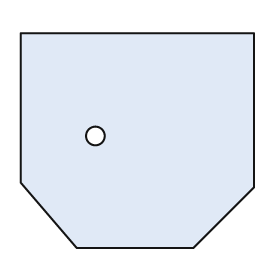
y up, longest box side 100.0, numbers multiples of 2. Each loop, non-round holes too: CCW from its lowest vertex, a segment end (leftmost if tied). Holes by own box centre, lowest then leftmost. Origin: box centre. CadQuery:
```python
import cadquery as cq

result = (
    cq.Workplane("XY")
    .moveTo(-26.0, -46.0)
    .lineTo(24.0, -46.0)
    .lineTo(50.0, -20.0)
    .lineTo(50.0, 46.0)
    .lineTo(-50.0, 46.0)
    .lineTo(-50.0, -18.0)
    .close()
    .moveTo(-18.0, 2.0)
    .circle(4.0)
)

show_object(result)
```